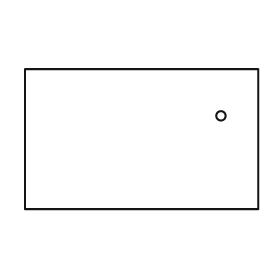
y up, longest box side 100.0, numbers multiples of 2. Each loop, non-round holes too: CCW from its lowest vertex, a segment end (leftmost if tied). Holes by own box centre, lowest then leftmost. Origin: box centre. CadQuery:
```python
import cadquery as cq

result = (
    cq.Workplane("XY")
    .moveTo(-50.0, -30.0)
    .lineTo(50.0, -30.0)
    .lineTo(50.0, 30.0)
    .lineTo(-50.0, 30.0)
    .close()
    .moveTo(34.0, 10.0)
    .circle(2.0)
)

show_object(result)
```